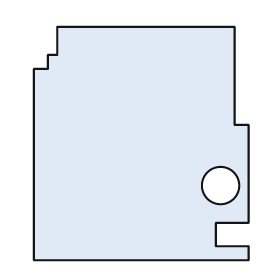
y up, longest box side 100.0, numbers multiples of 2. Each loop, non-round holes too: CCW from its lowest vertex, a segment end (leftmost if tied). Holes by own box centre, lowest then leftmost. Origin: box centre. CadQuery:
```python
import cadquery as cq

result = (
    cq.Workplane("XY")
    .moveTo(-46.0, -50.0)
    .lineTo(46.0, -50.0)
    .lineTo(46.0, -44.0)
    .lineTo(32.0, -44.0)
    .lineTo(32.0, -34.0)
    .lineTo(46.0, -34.0)
    .lineTo(46.0, 8.0)
    .lineTo(40.0, 8.0)
    .lineTo(40.0, 50.0)
    .lineTo(-36.0, 50.0)
    .lineTo(-36.0, 38.0)
    .lineTo(-40.0, 38.0)
    .lineTo(-40.0, 32.0)
    .lineTo(-46.0, 32.0)
    .close()
    .moveTo(34.0, -18.0)
    .circle(8.0)
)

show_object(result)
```